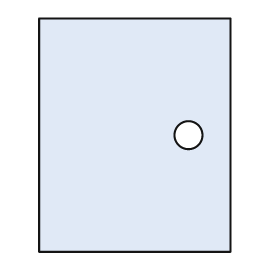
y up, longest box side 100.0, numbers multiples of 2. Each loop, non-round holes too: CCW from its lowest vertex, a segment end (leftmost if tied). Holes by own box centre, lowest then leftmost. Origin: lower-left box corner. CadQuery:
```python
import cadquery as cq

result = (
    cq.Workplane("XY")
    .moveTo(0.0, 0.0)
    .lineTo(82.0, 0.0)
    .lineTo(82.0, 100.0)
    .lineTo(0.0, 100.0)
    .close()
    .moveTo(64.0, 50.0)
    .circle(6.0)
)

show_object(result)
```